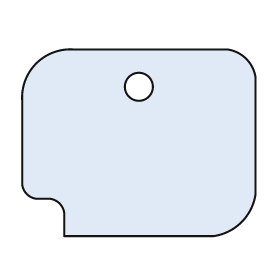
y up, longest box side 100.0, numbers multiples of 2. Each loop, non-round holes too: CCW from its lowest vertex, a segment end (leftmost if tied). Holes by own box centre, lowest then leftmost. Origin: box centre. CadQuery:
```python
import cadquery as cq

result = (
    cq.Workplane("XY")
    .moveTo(-32.0, -40.0)
    .lineTo(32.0, -40.0)
    .threePointArc((44.0, -34.0), (50.0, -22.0))
    .lineTo(50.0, 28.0)
    .threePointArc((46.0, 36.0), (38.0, 40.0))
    .lineTo(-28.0, 40.0)
    .threePointArc((-44.0, 34.0), (-50.0, 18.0))
    .lineTo(-50.0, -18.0)
    .threePointArc((-48.0, -22.0), (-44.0, -24.0))
    .lineTo(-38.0, -24.0)
    .threePointArc((-34.0, -26.0), (-32.0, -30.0))
    .close()
    .moveTo(0.0, 24.0)
    .circle(6.0)
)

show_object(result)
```